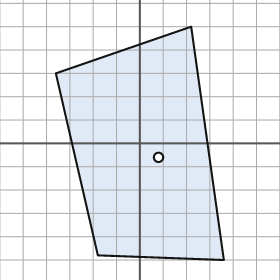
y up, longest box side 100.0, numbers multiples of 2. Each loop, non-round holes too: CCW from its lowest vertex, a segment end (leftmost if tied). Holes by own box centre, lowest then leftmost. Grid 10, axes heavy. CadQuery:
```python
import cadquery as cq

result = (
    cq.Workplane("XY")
    .moveTo(36.0, -50.0)
    .lineTo(22.0, 50.0)
    .lineTo(-36.0, 30.0)
    .lineTo(-18.0, -48.0)
    .close()
    .moveTo(8.0, -6.0)
    .circle(2.0)
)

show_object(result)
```